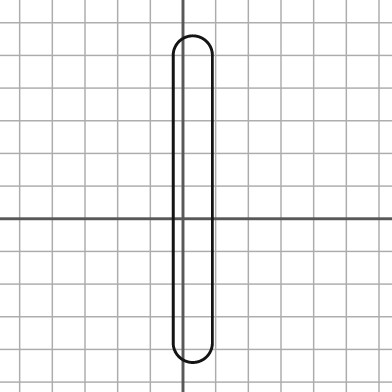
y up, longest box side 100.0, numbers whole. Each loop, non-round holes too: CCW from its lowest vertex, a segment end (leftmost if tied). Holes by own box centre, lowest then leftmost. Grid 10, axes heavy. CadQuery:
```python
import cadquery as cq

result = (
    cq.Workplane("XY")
    .moveTo(-3.0, -38.0)
    .threePointArc((3.0, -44.0), (9.0, -38.0))
    .lineTo(9.0, 50.0)
    .threePointArc((3.0, 56.0), (-3.0, 50.0))
    .close()
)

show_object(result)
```